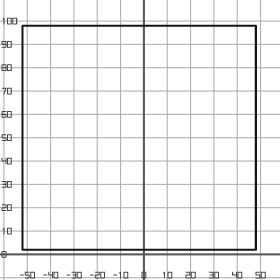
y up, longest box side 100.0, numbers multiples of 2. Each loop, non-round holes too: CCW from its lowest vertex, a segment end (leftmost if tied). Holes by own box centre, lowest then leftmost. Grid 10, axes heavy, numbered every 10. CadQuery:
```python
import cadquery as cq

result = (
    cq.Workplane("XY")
    .moveTo(-52.0, 2.0)
    .lineTo(48.0, 2.0)
    .lineTo(48.0, 98.0)
    .lineTo(-52.0, 98.0)
    .close()
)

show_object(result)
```